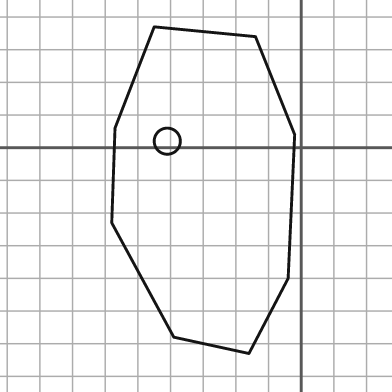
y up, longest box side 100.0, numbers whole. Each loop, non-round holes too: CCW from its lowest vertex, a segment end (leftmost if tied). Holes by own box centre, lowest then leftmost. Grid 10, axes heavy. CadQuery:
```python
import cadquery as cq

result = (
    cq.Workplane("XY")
    .moveTo(-16.0, -63.0)
    .lineTo(-4.0, -40.0)
    .lineTo(-2.0, 4.0)
    .lineTo(-14.0, 34.0)
    .lineTo(-45.0, 37.0)
    .lineTo(-57.0, 6.0)
    .lineTo(-58.0, -23.0)
    .lineTo(-39.0, -58.0)
    .close()
    .moveTo(-41.0, 2.0)
    .circle(4.0)
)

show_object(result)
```